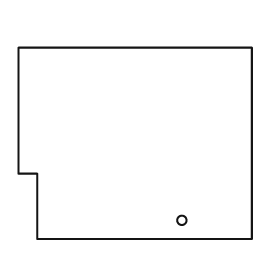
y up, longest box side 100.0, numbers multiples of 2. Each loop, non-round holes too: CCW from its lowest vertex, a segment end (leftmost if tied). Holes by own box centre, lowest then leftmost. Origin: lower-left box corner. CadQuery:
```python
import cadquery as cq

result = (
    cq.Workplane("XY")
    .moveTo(8.0, 0.0)
    .lineTo(100.0, 0.0)
    .lineTo(100.0, 82.0)
    .lineTo(0.0, 82.0)
    .lineTo(0.0, 28.0)
    .lineTo(8.0, 28.0)
    .close()
    .moveTo(70.0, 8.0)
    .circle(2.0)
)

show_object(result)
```